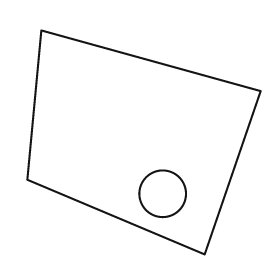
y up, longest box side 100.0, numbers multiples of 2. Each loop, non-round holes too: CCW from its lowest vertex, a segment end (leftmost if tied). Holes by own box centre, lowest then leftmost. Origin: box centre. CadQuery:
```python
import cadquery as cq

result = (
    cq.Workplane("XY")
    .moveTo(26.0, -48.0)
    .lineTo(50.0, 22.0)
    .lineTo(-44.0, 48.0)
    .lineTo(-50.0, -16.0)
    .close()
    .moveTo(8.0, -22.0)
    .circle(10.0)
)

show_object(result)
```